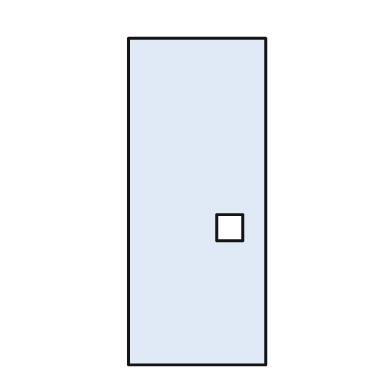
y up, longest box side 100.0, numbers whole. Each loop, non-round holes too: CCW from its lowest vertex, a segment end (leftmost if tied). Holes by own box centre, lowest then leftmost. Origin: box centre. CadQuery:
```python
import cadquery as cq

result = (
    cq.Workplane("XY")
    .moveTo(-21.0, -50.0)
    .lineTo(21.0, -50.0)
    .lineTo(21.0, 50.0)
    .lineTo(-21.0, 50.0)
    .close()
    .moveTo(6.0, -12.0)
    .lineTo(14.0, -12.0)
    .lineTo(14.0, -4.0)
    .lineTo(6.0, -4.0)
    .close()
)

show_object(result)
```